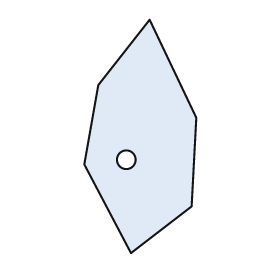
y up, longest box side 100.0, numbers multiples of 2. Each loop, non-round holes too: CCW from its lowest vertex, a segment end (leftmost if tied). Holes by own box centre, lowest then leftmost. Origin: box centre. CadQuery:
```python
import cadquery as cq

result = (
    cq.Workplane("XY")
    .moveTo(-4.0, -50.0)
    .lineTo(22.0, -30.0)
    .lineTo(24.0, 8.0)
    .lineTo(4.0, 50.0)
    .lineTo(-18.0, 22.0)
    .lineTo(-24.0, -12.0)
    .close()
    .moveTo(-6.0, -10.0)
    .circle(4.0)
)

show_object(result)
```